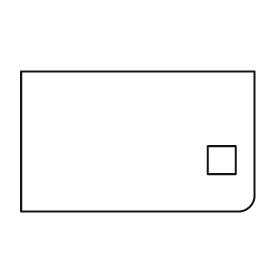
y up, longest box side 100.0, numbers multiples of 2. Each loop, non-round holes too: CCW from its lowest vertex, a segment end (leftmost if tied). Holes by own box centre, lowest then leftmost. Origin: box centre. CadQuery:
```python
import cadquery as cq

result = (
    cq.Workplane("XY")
    .moveTo(-50.0, -30.0)
    .lineTo(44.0, -30.0)
    .threePointArc((48.0, -28.0), (50.0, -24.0))
    .lineTo(50.0, 30.0)
    .lineTo(-50.0, 30.0)
    .close()
    .moveTo(30.0, -14.0)
    .lineTo(42.0, -14.0)
    .lineTo(42.0, -2.0)
    .lineTo(30.0, -2.0)
    .close()
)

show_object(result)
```